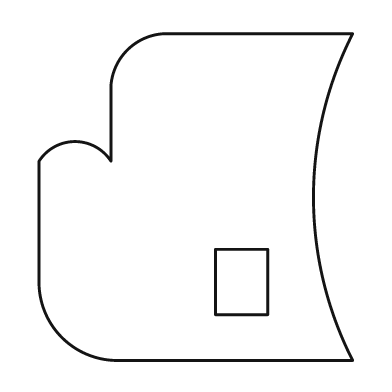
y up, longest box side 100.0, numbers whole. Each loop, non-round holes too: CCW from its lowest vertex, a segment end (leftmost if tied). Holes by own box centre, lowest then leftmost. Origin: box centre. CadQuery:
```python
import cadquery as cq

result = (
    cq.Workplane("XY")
    .moveTo(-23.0, -50.0)
    .lineTo(48.0, -50.0)
    .threePointArc((36.0, 0.0), (48.0, 50.0))
    .lineTo(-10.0, 50.0)
    .threePointArc((-21.0, 45.0), (-26.0, 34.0))
    .lineTo(-26.0, 11.0)
    .threePointArc((-37.0, 17.0), (-48.0, 11.0))
    .lineTo(-48.0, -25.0)
    .threePointArc((-41.0, -43.0), (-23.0, -50.0))
    .close()
    .moveTo(6.0, -36.0)
    .lineTo(22.0, -36.0)
    .lineTo(22.0, -16.0)
    .lineTo(6.0, -16.0)
    .close()
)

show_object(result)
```